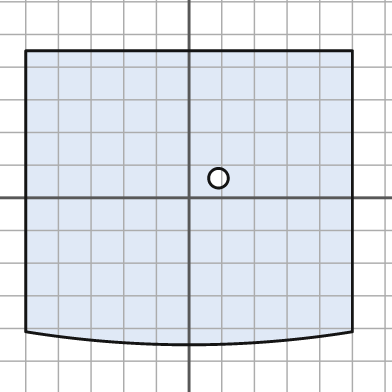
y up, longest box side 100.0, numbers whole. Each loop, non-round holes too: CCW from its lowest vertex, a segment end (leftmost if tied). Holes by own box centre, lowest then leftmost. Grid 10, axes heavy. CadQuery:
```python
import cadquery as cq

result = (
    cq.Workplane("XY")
    .moveTo(-50.0, -41.0)
    .threePointArc((0.0, -45.0), (50.0, -41.0))
    .lineTo(50.0, 45.0)
    .lineTo(-50.0, 45.0)
    .close()
    .moveTo(9.0, 6.0)
    .circle(3.0)
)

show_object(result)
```